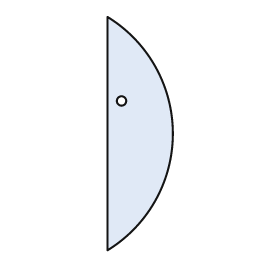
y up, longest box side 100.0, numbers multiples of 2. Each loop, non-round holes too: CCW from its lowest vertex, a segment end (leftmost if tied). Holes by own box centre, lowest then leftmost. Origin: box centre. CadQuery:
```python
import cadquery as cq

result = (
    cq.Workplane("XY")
    .moveTo(-14.0, -50.0)
    .threePointArc((14.0, 0.0), (-14.0, 50.0))
    .close()
    .moveTo(-8.0, 14.0)
    .circle(2.0)
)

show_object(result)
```